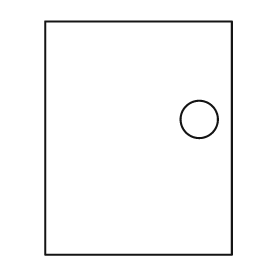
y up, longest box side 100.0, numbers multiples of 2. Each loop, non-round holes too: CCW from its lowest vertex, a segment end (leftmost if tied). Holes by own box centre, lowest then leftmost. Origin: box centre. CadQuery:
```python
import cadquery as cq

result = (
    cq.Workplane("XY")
    .moveTo(-40.0, -50.0)
    .lineTo(40.0, -50.0)
    .lineTo(40.0, 50.0)
    .lineTo(-40.0, 50.0)
    .close()
    .moveTo(26.0, 8.0)
    .circle(8.0)
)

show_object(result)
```